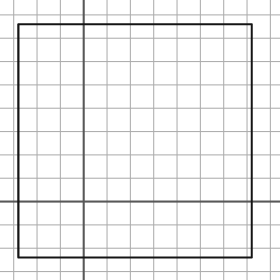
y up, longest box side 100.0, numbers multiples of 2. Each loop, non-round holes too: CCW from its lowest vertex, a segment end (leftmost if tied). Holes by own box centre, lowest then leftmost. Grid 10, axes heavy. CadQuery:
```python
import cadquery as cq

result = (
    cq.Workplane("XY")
    .moveTo(-28.0, -24.0)
    .lineTo(72.0, -24.0)
    .lineTo(72.0, 76.0)
    .lineTo(-28.0, 76.0)
    .close()
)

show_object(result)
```